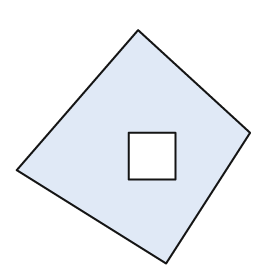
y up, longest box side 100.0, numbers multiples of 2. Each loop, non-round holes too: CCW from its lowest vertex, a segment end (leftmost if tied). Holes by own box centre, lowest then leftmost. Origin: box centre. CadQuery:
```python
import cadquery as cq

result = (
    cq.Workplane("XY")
    .moveTo(14.0, -50.0)
    .lineTo(50.0, 6.0)
    .lineTo(2.0, 50.0)
    .lineTo(-50.0, -10.0)
    .close()
    .moveTo(-2.0, -14.0)
    .lineTo(18.0, -14.0)
    .lineTo(18.0, 6.0)
    .lineTo(-2.0, 6.0)
    .close()
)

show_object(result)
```